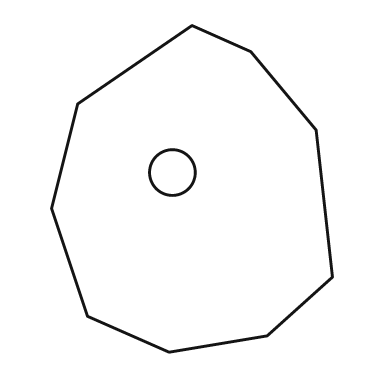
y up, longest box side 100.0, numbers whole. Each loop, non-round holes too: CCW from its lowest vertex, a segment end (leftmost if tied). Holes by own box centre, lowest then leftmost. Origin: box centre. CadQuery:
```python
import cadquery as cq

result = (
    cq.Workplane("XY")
    .moveTo(-7.0, -50.0)
    .lineTo(23.0, -45.0)
    .lineTo(43.0, -27.0)
    .lineTo(38.0, 18.0)
    .lineTo(18.0, 42.0)
    .lineTo(0.0, 50.0)
    .lineTo(-35.0, 26.0)
    .lineTo(-43.0, -6.0)
    .lineTo(-32.0, -39.0)
    .close()
    .moveTo(-6.0, 5.0)
    .circle(7.0)
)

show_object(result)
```